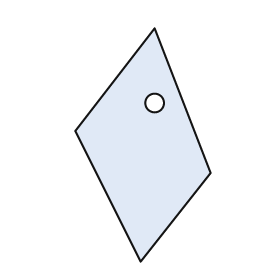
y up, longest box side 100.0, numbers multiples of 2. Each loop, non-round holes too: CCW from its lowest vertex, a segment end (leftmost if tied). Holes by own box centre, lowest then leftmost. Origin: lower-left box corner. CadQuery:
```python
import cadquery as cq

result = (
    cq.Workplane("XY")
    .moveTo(28.0, 0.0)
    .lineTo(58.0, 38.0)
    .lineTo(34.0, 100.0)
    .lineTo(0.0, 56.0)
    .close()
    .moveTo(34.0, 68.0)
    .circle(4.0)
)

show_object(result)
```